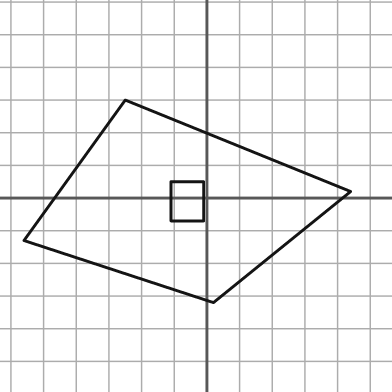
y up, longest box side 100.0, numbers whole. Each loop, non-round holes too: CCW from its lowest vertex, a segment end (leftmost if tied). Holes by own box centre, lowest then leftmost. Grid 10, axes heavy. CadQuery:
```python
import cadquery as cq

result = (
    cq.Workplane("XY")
    .moveTo(2.0, -32.0)
    .lineTo(44.0, 2.0)
    .lineTo(-25.0, 30.0)
    .lineTo(-56.0, -13.0)
    .close()
    .moveTo(-11.0, -7.0)
    .lineTo(-1.0, -7.0)
    .lineTo(-1.0, 5.0)
    .lineTo(-11.0, 5.0)
    .close()
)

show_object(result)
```